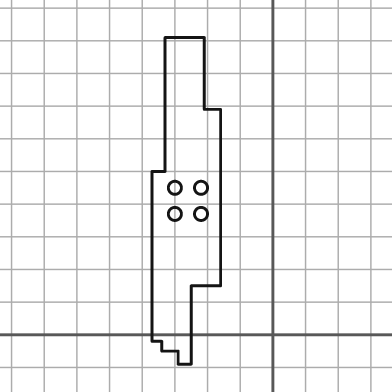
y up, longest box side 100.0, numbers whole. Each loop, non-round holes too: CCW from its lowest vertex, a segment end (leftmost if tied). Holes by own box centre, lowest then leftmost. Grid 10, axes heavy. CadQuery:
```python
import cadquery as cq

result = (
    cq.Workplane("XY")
    .moveTo(-29.0, -9.0)
    .lineTo(-25.0, -9.0)
    .lineTo(-25.0, 15.0)
    .lineTo(-16.0, 15.0)
    .lineTo(-16.0, 69.0)
    .lineTo(-21.0, 69.0)
    .lineTo(-21.0, 91.0)
    .lineTo(-33.0, 91.0)
    .lineTo(-33.0, 50.0)
    .lineTo(-37.0, 50.0)
    .lineTo(-37.0, -2.0)
    .lineTo(-34.0, -2.0)
    .lineTo(-34.0, -5.0)
    .lineTo(-29.0, -5.0)
    .close()
    .moveTo(-30.0, 37.0)
    .circle(2.0)
    .moveTo(-22.0, 37.0)
    .circle(2.0)
    .moveTo(-30.0, 45.0)
    .circle(2.0)
    .moveTo(-22.0, 45.0)
    .circle(2.0)
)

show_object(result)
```